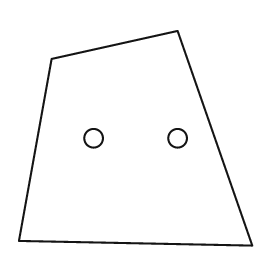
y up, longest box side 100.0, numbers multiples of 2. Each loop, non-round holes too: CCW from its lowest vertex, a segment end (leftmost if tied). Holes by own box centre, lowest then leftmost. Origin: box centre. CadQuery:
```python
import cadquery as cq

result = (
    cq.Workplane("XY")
    .moveTo(50.0, -46.0)
    .lineTo(18.0, 46.0)
    .lineTo(-36.0, 34.0)
    .lineTo(-50.0, -44.0)
    .close()
    .moveTo(-18.0, 0.0)
    .circle(4.0)
    .moveTo(18.0, 0.0)
    .circle(4.0)
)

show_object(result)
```